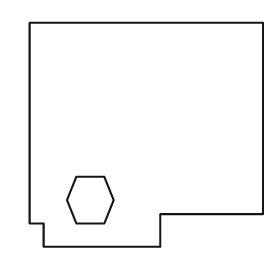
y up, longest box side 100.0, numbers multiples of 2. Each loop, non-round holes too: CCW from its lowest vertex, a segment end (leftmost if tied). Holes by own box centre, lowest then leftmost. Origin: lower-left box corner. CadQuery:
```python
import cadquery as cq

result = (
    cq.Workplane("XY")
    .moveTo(6.0, 0.0)
    .lineTo(56.0, 0.0)
    .lineTo(56.0, 14.0)
    .lineTo(100.0, 14.0)
    .lineTo(100.0, 96.0)
    .lineTo(0.0, 96.0)
    .lineTo(0.0, 10.0)
    .lineTo(6.0, 10.0)
    .close()
    .moveTo(20.0, 10.0)
    .lineTo(32.0, 10.0)
    .lineTo(36.0, 20.0)
    .lineTo(32.0, 30.0)
    .lineTo(20.0, 30.0)
    .lineTo(16.0, 20.0)
    .close()
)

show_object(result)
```